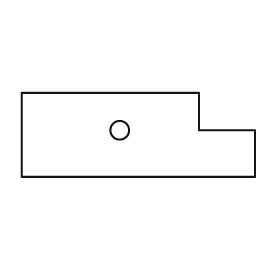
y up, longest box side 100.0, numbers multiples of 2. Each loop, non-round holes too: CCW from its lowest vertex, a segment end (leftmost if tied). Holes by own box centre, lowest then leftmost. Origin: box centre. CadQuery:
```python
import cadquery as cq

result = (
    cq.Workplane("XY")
    .moveTo(-50.0, -18.0)
    .lineTo(50.0, -18.0)
    .lineTo(50.0, 2.0)
    .lineTo(26.0, 2.0)
    .lineTo(26.0, 18.0)
    .lineTo(-50.0, 18.0)
    .close()
    .moveTo(-8.0, 2.0)
    .circle(4.0)
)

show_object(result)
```